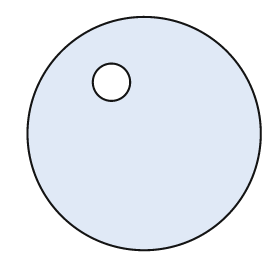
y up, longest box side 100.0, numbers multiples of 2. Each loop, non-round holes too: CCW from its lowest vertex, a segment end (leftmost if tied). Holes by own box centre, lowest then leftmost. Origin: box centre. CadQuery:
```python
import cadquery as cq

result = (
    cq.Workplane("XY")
    .moveTo(0.0, 0.0)
    .circle(50.0)
    .moveTo(-14.0, 22.0)
    .circle(8.0)
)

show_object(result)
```